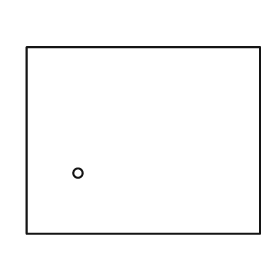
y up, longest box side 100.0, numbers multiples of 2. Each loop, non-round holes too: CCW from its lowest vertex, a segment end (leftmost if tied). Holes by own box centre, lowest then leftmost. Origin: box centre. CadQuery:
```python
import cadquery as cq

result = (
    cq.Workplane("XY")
    .moveTo(-50.0, -40.0)
    .lineTo(50.0, -40.0)
    .lineTo(50.0, 40.0)
    .lineTo(-50.0, 40.0)
    .close()
    .moveTo(-28.0, -14.0)
    .circle(2.0)
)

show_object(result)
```